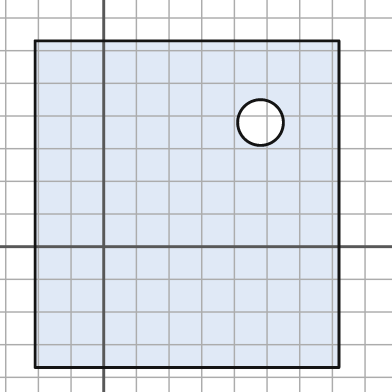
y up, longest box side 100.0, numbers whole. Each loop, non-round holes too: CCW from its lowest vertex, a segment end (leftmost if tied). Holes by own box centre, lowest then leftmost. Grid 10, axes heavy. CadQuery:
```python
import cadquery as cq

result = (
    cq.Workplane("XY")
    .moveTo(-21.0, -37.0)
    .lineTo(72.0, -37.0)
    .lineTo(72.0, 63.0)
    .lineTo(-21.0, 63.0)
    .close()
    .moveTo(48.0, 38.0)
    .circle(7.0)
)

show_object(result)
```